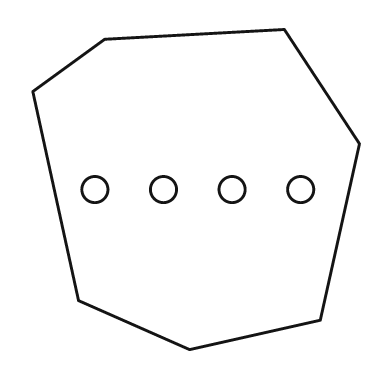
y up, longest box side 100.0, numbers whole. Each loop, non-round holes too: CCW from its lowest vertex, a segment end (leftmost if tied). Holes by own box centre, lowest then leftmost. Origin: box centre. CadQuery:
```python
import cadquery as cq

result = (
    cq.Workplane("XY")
    .moveTo(-2.0, -49.0)
    .lineTo(38.0, -40.0)
    .lineTo(50.0, 14.0)
    .lineTo(27.0, 49.0)
    .lineTo(-28.0, 46.0)
    .lineTo(-50.0, 30.0)
    .lineTo(-36.0, -34.0)
    .close()
    .moveTo(-31.0, 0.0)
    .circle(4.0)
    .moveTo(-10.0, 0.0)
    .circle(4.0)
    .moveTo(11.0, 0.0)
    .circle(4.0)
    .moveTo(32.0, 0.0)
    .circle(4.0)
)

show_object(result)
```